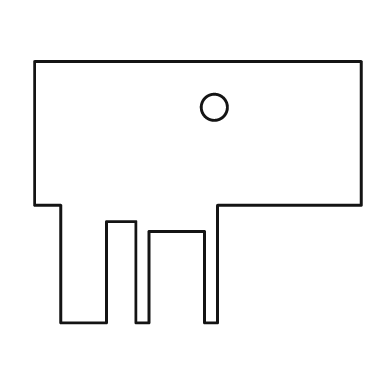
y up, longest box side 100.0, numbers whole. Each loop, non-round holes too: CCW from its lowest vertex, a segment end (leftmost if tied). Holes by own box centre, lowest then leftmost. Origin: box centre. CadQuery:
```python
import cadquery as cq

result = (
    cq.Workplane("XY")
    .moveTo(-42.0, -40.0)
    .lineTo(-28.0, -40.0)
    .lineTo(-28.0, -9.0)
    .lineTo(-19.0, -9.0)
    .lineTo(-19.0, -40.0)
    .lineTo(-15.0, -40.0)
    .lineTo(-15.0, -12.0)
    .lineTo(2.0, -12.0)
    .lineTo(2.0, -40.0)
    .lineTo(6.0, -40.0)
    .lineTo(6.0, -4.0)
    .lineTo(50.0, -4.0)
    .lineTo(50.0, 40.0)
    .lineTo(-50.0, 40.0)
    .lineTo(-50.0, -4.0)
    .lineTo(-42.0, -4.0)
    .close()
    .moveTo(5.0, 26.0)
    .circle(4.0)
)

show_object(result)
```